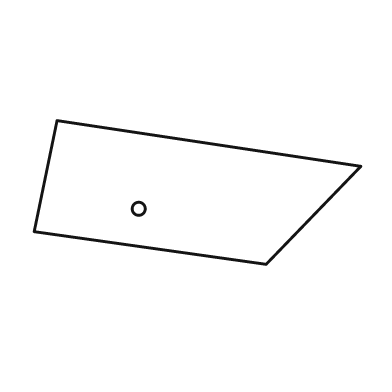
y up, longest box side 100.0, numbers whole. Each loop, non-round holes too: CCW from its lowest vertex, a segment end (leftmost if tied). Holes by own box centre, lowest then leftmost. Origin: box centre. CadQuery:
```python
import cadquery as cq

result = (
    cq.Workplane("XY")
    .moveTo(21.0, -22.0)
    .lineTo(50.0, 8.0)
    .lineTo(-43.0, 22.0)
    .lineTo(-50.0, -12.0)
    .close()
    .moveTo(-18.0, -5.0)
    .circle(2.0)
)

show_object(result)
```